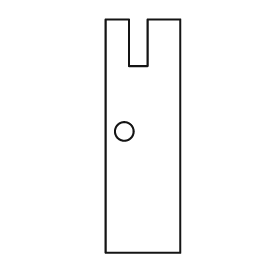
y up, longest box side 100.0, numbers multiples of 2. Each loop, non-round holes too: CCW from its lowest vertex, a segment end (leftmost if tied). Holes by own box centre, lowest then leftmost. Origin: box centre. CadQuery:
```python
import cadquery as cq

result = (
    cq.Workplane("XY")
    .moveTo(-16.0, -50.0)
    .lineTo(16.0, -50.0)
    .lineTo(16.0, 50.0)
    .lineTo(2.0, 50.0)
    .lineTo(2.0, 30.0)
    .lineTo(-6.0, 30.0)
    .lineTo(-6.0, 50.0)
    .lineTo(-16.0, 50.0)
    .close()
    .moveTo(-8.0, 2.0)
    .circle(4.0)
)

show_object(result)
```